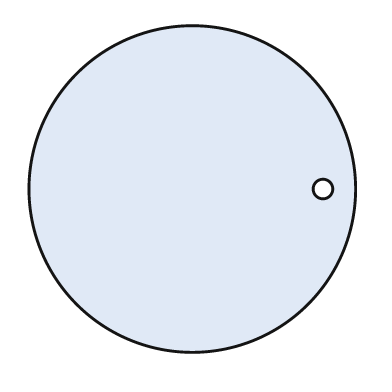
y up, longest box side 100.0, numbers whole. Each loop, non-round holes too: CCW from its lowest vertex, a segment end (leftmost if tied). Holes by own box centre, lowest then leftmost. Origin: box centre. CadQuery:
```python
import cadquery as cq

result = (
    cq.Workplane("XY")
    .moveTo(0.0, 0.0)
    .circle(50.0)
    .moveTo(40.0, 0.0)
    .circle(3.0)
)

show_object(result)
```